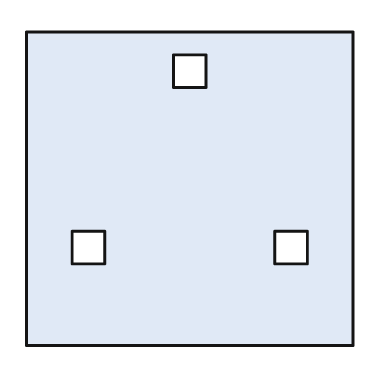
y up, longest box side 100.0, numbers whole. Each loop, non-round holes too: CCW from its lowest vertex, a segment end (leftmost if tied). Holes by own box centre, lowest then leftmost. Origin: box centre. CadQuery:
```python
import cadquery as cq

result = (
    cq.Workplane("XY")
    .moveTo(-50.0, -48.0)
    .lineTo(50.0, -48.0)
    .lineTo(50.0, 48.0)
    .lineTo(-50.0, 48.0)
    .close()
    .moveTo(-36.0, -23.0)
    .lineTo(-26.0, -23.0)
    .lineTo(-26.0, -13.0)
    .lineTo(-36.0, -13.0)
    .close()
    .moveTo(26.0, -23.0)
    .lineTo(36.0, -23.0)
    .lineTo(36.0, -13.0)
    .lineTo(26.0, -13.0)
    .close()
    .moveTo(-5.0, 31.0)
    .lineTo(5.0, 31.0)
    .lineTo(5.0, 41.0)
    .lineTo(-5.0, 41.0)
    .close()
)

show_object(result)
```